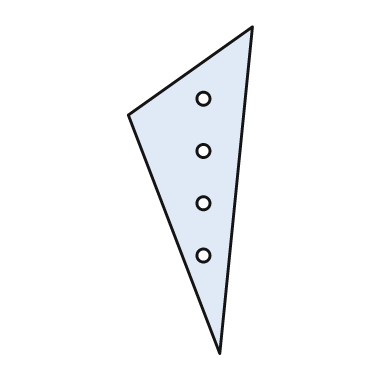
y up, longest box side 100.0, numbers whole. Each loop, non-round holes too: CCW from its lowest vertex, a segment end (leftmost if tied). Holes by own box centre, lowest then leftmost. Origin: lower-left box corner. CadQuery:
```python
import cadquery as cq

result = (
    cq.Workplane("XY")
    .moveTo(28.0, 0.0)
    .lineTo(38.0, 100.0)
    .lineTo(0.0, 73.0)
    .close()
    .moveTo(23.0, 30.0)
    .circle(2.0)
    .moveTo(23.0, 46.0)
    .circle(2.0)
    .moveTo(23.0, 62.0)
    .circle(2.0)
    .moveTo(23.0, 78.0)
    .circle(2.0)
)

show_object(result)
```